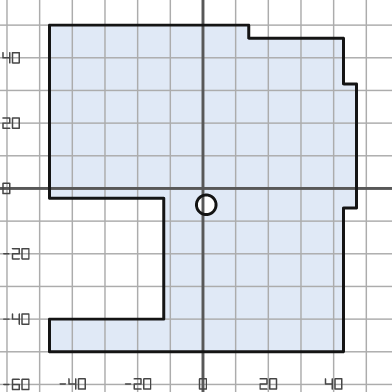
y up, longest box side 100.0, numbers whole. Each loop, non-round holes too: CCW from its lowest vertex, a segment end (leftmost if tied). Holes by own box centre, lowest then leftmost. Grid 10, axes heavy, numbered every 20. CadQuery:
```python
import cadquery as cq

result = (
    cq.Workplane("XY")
    .moveTo(-47.0, -50.0)
    .lineTo(43.0, -50.0)
    .lineTo(43.0, -6.0)
    .lineTo(47.0, -6.0)
    .lineTo(47.0, 32.0)
    .lineTo(43.0, 32.0)
    .lineTo(43.0, 46.0)
    .lineTo(14.0, 46.0)
    .lineTo(14.0, 50.0)
    .lineTo(-47.0, 50.0)
    .lineTo(-47.0, -3.0)
    .lineTo(-12.0, -3.0)
    .lineTo(-12.0, -40.0)
    .lineTo(-47.0, -40.0)
    .close()
    .moveTo(1.0, -5.0)
    .circle(3.0)
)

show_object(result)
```